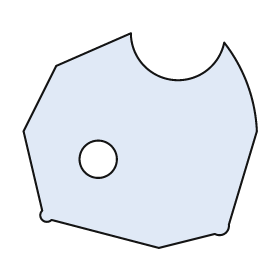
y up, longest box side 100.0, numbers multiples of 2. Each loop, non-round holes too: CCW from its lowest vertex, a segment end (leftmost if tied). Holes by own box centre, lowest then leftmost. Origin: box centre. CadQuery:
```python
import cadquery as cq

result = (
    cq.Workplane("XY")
    .moveTo(8.0, -46.0)
    .lineTo(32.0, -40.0)
    .threePointArc((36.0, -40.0), (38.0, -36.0))
    .lineTo(50.0, 4.0)
    .threePointArc((46.0, 24.0), (36.0, 42.0))
    .threePointArc((14.0, 26.0), (-4.0, 46.0))
    .lineTo(-36.0, 32.0)
    .lineTo(-50.0, 4.0)
    .lineTo(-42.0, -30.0)
    .threePointArc((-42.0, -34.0), (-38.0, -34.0))
    .close()
    .moveTo(-18.0, -8.0)
    .circle(8.0)
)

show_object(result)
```